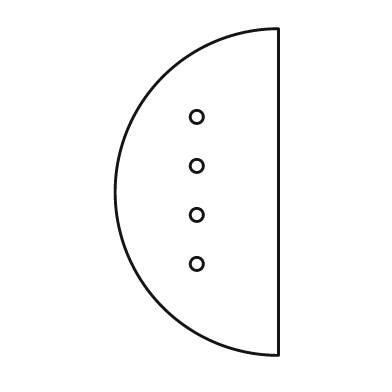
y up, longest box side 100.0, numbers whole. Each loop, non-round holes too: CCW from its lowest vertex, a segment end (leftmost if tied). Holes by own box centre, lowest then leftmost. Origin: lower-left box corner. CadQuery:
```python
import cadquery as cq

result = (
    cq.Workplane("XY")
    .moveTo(50.0, 0.0)
    .lineTo(50.0, 100.0)
    .threePointArc((0.0, 50.0), (50.0, 0.0))
    .close()
    .moveTo(25.0, 28.0)
    .circle(2.0)
    .moveTo(25.0, 43.0)
    .circle(2.0)
    .moveTo(25.0, 58.0)
    .circle(2.0)
    .moveTo(25.0, 73.0)
    .circle(2.0)
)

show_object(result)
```